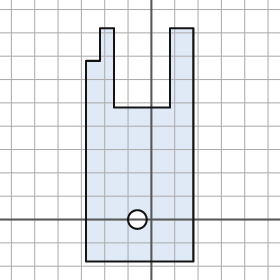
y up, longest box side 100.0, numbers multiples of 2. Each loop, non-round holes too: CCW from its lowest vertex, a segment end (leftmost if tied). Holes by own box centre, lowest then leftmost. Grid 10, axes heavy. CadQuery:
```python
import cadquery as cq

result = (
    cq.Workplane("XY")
    .moveTo(-28.0, -18.0)
    .lineTo(18.0, -18.0)
    .lineTo(18.0, 82.0)
    .lineTo(8.0, 82.0)
    .lineTo(8.0, 48.0)
    .lineTo(-16.0, 48.0)
    .lineTo(-16.0, 82.0)
    .lineTo(-22.0, 82.0)
    .lineTo(-22.0, 68.0)
    .lineTo(-28.0, 68.0)
    .close()
    .moveTo(-6.0, 0.0)
    .circle(4.0)
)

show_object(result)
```